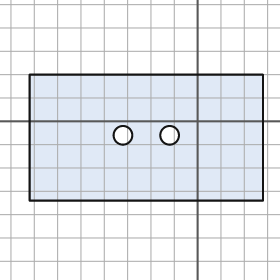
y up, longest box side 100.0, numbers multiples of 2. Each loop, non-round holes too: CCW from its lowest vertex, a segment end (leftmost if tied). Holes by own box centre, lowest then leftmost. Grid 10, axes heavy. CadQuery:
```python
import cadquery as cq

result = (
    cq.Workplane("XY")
    .moveTo(-72.0, -34.0)
    .lineTo(28.0, -34.0)
    .lineTo(28.0, 20.0)
    .lineTo(-72.0, 20.0)
    .close()
    .moveTo(-32.0, -6.0)
    .circle(4.0)
    .moveTo(-12.0, -6.0)
    .circle(4.0)
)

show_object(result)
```